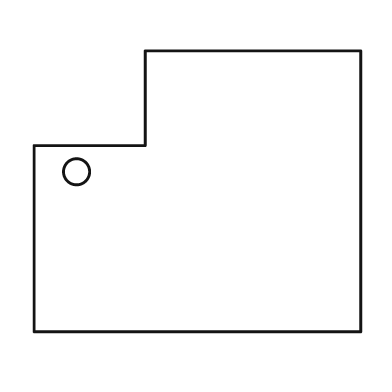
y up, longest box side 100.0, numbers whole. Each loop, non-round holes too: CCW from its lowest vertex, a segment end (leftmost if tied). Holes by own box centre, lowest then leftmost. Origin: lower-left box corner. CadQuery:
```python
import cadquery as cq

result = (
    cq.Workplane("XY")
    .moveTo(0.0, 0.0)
    .lineTo(100.0, 0.0)
    .lineTo(100.0, 86.0)
    .lineTo(34.0, 86.0)
    .lineTo(34.0, 57.0)
    .lineTo(0.0, 57.0)
    .close()
    .moveTo(13.0, 49.0)
    .circle(4.0)
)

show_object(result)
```